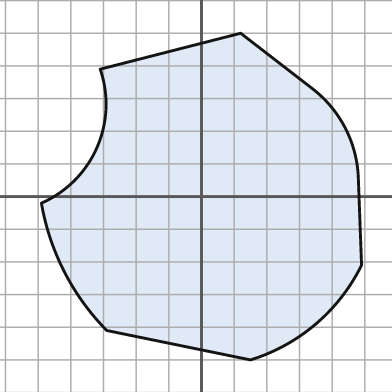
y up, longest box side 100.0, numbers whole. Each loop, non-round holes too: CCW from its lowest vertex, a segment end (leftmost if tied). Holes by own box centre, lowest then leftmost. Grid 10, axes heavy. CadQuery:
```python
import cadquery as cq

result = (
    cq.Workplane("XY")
    .moveTo(15.0, -50.0)
    .threePointArc((35.0, -39.0), (49.0, -21.0))
    .lineTo(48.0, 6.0)
    .threePointArc((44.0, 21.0), (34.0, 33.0))
    .lineTo(12.0, 50.0)
    .lineTo(-31.0, 39.0)
    .threePointArc((-32.0, 15.0), (-49.0, -2.0))
    .threePointArc((-42.0, -23.0), (-29.0, -41.0))
    .close()
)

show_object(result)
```